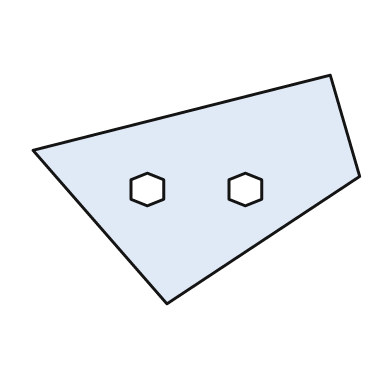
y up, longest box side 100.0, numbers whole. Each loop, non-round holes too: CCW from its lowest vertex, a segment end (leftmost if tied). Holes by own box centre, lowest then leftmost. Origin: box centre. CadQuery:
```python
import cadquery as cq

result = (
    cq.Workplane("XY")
    .moveTo(-9.0, -35.0)
    .lineTo(50.0, 4.0)
    .lineTo(41.0, 35.0)
    .lineTo(-50.0, 12.0)
    .close()
    .moveTo(-15.0, -5.0)
    .lineTo(-10.0, -3.0)
    .lineTo(-10.0, 3.0)
    .lineTo(-15.0, 5.0)
    .lineTo(-20.0, 3.0)
    .lineTo(-20.0, -3.0)
    .close()
    .moveTo(15.0, -5.0)
    .lineTo(20.0, -3.0)
    .lineTo(20.0, 3.0)
    .lineTo(15.0, 5.0)
    .lineTo(10.0, 3.0)
    .lineTo(10.0, -3.0)
    .close()
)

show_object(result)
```